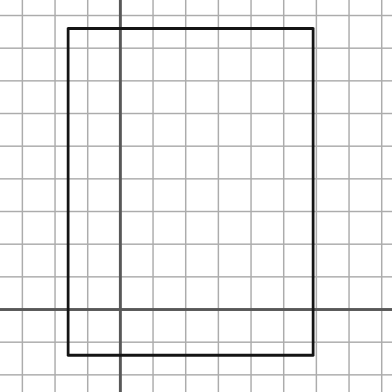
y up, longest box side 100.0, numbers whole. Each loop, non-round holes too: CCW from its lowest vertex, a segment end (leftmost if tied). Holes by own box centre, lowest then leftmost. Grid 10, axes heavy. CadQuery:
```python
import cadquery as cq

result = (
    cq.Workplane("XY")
    .moveTo(-16.0, -14.0)
    .lineTo(59.0, -14.0)
    .lineTo(59.0, 86.0)
    .lineTo(-16.0, 86.0)
    .close()
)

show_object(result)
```